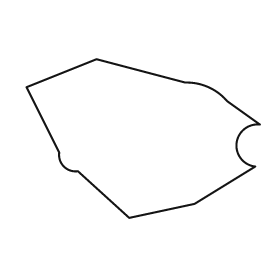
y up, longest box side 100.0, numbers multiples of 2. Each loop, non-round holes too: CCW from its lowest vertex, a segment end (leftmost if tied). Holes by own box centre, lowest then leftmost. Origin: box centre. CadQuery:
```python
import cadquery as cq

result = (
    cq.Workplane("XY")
    .moveTo(-6.0, -34.0)
    .lineTo(22.0, -28.0)
    .lineTo(48.0, -12.0)
    .threePointArc((40.0, -2.0), (50.0, 6.0))
    .lineTo(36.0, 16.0)
    .threePointArc((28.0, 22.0), (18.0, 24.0))
    .lineTo(-20.0, 34.0)
    .lineTo(-50.0, 22.0)
    .lineTo(-36.0, -6.0)
    .threePointArc((-34.0, -12.0), (-28.0, -14.0))
    .close()
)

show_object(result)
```